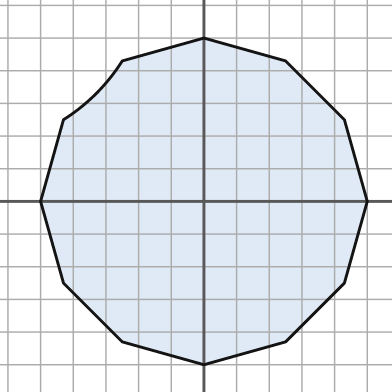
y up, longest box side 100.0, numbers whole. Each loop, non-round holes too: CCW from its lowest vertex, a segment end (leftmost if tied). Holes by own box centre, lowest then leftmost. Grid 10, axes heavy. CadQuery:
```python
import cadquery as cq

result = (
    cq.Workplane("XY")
    .moveTo(0.0, -50.0)
    .lineTo(25.0, -43.0)
    .lineTo(43.0, -25.0)
    .lineTo(50.0, 0.0)
    .lineTo(43.0, 25.0)
    .lineTo(25.0, 43.0)
    .lineTo(0.0, 50.0)
    .lineTo(-25.0, 43.0)
    .threePointArc((-33.0, 33.0), (-43.0, 25.0))
    .lineTo(-50.0, 0.0)
    .lineTo(-43.0, -25.0)
    .lineTo(-25.0, -43.0)
    .close()
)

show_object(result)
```